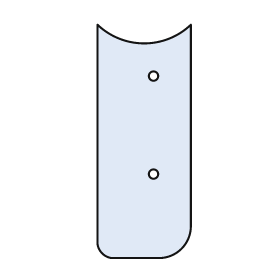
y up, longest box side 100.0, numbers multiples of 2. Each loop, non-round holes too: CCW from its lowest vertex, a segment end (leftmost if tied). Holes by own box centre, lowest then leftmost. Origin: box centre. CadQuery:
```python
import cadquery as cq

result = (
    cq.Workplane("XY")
    .moveTo(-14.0, -50.0)
    .lineTo(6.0, -50.0)
    .threePointArc((16.0, -46.0), (20.0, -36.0))
    .lineTo(20.0, 50.0)
    .threePointArc((0.0, 42.0), (-20.0, 50.0))
    .lineTo(-20.0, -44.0)
    .threePointArc((-18.0, -48.0), (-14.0, -50.0))
    .close()
    .moveTo(4.0, -14.0)
    .circle(2.0)
    .moveTo(4.0, 28.0)
    .circle(2.0)
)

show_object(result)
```